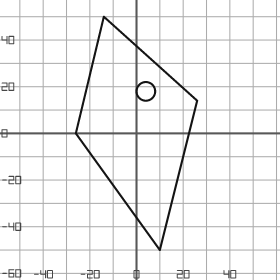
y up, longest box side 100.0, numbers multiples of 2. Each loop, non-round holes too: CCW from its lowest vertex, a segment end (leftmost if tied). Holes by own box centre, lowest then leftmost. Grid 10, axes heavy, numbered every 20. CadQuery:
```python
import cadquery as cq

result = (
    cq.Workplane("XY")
    .moveTo(10.0, -50.0)
    .lineTo(26.0, 14.0)
    .lineTo(-14.0, 50.0)
    .lineTo(-26.0, 0.0)
    .close()
    .moveTo(4.0, 18.0)
    .circle(4.0)
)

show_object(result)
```